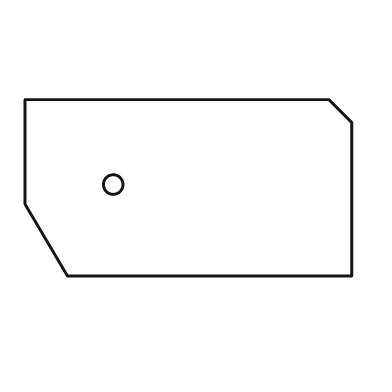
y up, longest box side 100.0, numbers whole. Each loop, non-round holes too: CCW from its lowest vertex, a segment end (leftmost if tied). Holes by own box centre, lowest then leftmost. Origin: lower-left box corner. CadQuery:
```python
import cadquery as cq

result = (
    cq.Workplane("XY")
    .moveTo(13.0, 0.0)
    .lineTo(100.0, 0.0)
    .lineTo(100.0, 47.0)
    .lineTo(93.0, 54.0)
    .lineTo(0.0, 54.0)
    .lineTo(0.0, 22.0)
    .close()
    .moveTo(27.0, 28.0)
    .circle(3.0)
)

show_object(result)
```